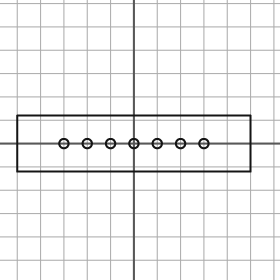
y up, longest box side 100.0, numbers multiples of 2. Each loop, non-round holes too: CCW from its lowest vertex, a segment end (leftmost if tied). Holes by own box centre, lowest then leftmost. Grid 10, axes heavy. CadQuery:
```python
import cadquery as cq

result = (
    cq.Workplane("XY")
    .moveTo(-50.0, -12.0)
    .lineTo(50.0, -12.0)
    .lineTo(50.0, 12.0)
    .lineTo(-50.0, 12.0)
    .close()
    .moveTo(-30.0, 0.0)
    .circle(2.0)
    .moveTo(-20.0, 0.0)
    .circle(2.0)
    .moveTo(-10.0, 0.0)
    .circle(2.0)
    .moveTo(0.0, 0.0)
    .circle(2.0)
    .moveTo(10.0, 0.0)
    .circle(2.0)
    .moveTo(20.0, 0.0)
    .circle(2.0)
    .moveTo(30.0, 0.0)
    .circle(2.0)
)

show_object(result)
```